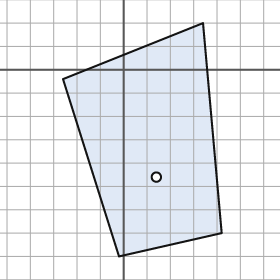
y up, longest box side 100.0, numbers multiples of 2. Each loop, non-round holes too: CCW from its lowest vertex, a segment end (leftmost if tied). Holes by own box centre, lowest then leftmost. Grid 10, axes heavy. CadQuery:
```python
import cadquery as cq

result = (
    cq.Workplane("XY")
    .moveTo(-2.0, -80.0)
    .lineTo(42.0, -70.0)
    .lineTo(34.0, 20.0)
    .lineTo(-26.0, -4.0)
    .close()
    .moveTo(14.0, -46.0)
    .circle(2.0)
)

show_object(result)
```